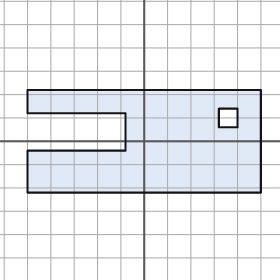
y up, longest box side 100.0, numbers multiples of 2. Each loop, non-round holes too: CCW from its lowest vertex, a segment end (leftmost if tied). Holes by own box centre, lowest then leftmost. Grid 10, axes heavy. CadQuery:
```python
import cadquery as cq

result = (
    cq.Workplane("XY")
    .moveTo(-50.0, -22.0)
    .lineTo(50.0, -22.0)
    .lineTo(50.0, 22.0)
    .lineTo(-50.0, 22.0)
    .lineTo(-50.0, 12.0)
    .lineTo(-8.0, 12.0)
    .lineTo(-8.0, -4.0)
    .lineTo(-50.0, -4.0)
    .close()
    .moveTo(32.0, 6.0)
    .lineTo(40.0, 6.0)
    .lineTo(40.0, 14.0)
    .lineTo(32.0, 14.0)
    .close()
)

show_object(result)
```